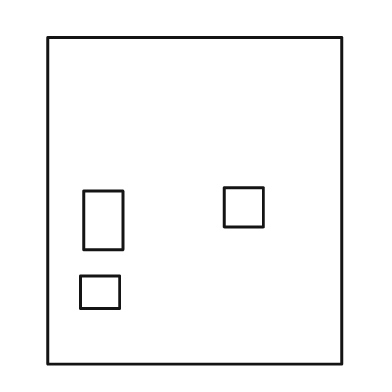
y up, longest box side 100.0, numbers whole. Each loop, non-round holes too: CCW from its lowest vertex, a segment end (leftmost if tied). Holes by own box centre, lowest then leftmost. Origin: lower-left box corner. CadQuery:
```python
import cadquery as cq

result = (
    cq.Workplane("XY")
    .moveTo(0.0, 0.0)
    .lineTo(90.0, 0.0)
    .lineTo(90.0, 100.0)
    .lineTo(0.0, 100.0)
    .close()
    .moveTo(10.0, 17.0)
    .lineTo(22.0, 17.0)
    .lineTo(22.0, 27.0)
    .lineTo(10.0, 27.0)
    .close()
    .moveTo(11.0, 35.0)
    .lineTo(23.0, 35.0)
    .lineTo(23.0, 53.0)
    .lineTo(11.0, 53.0)
    .close()
    .moveTo(54.0, 42.0)
    .lineTo(66.0, 42.0)
    .lineTo(66.0, 54.0)
    .lineTo(54.0, 54.0)
    .close()
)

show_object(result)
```